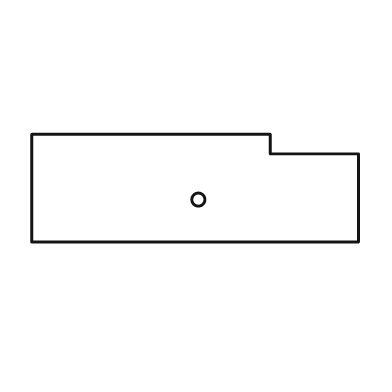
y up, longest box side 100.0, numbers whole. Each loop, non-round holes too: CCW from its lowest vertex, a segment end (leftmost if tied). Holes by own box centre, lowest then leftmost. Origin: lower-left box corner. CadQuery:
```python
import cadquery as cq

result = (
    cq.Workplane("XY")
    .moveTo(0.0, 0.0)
    .lineTo(100.0, 0.0)
    .lineTo(100.0, 27.0)
    .lineTo(73.0, 27.0)
    .lineTo(73.0, 33.0)
    .lineTo(0.0, 33.0)
    .close()
    .moveTo(51.0, 13.0)
    .circle(2.0)
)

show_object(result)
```